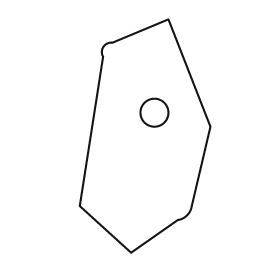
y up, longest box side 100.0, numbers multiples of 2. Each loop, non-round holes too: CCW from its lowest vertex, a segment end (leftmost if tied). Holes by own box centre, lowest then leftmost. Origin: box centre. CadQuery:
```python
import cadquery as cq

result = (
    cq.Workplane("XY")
    .moveTo(-6.0, -50.0)
    .lineTo(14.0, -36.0)
    .threePointArc((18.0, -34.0), (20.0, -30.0))
    .lineTo(28.0, 4.0)
    .lineTo(10.0, 50.0)
    .lineTo(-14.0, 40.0)
    .threePointArc((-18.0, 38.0), (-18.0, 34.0))
    .lineTo(-28.0, -30.0)
    .close()
    .moveTo(4.0, 10.0)
    .circle(6.0)
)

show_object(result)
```